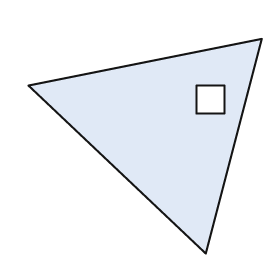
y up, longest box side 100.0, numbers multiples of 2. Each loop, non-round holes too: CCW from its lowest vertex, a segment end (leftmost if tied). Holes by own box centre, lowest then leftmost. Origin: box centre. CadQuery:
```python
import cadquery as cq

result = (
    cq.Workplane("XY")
    .moveTo(26.0, -46.0)
    .lineTo(50.0, 46.0)
    .lineTo(-50.0, 26.0)
    .close()
    .moveTo(22.0, 14.0)
    .lineTo(34.0, 14.0)
    .lineTo(34.0, 26.0)
    .lineTo(22.0, 26.0)
    .close()
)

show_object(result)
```